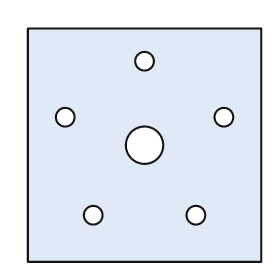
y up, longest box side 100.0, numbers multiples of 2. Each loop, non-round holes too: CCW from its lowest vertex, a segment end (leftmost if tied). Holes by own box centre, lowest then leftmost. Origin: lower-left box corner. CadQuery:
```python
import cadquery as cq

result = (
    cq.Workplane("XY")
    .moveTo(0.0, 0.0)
    .lineTo(100.0, 0.0)
    .lineTo(100.0, 100.0)
    .lineTo(0.0, 100.0)
    .close()
    .moveTo(28.0, 20.0)
    .circle(4.0)
    .moveTo(72.0, 20.0)
    .circle(4.0)
    .moveTo(50.0, 50.0)
    .circle(8.0)
    .moveTo(16.0, 62.0)
    .circle(4.0)
    .moveTo(84.0, 62.0)
    .circle(4.0)
    .moveTo(50.0, 86.0)
    .circle(4.0)
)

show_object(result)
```